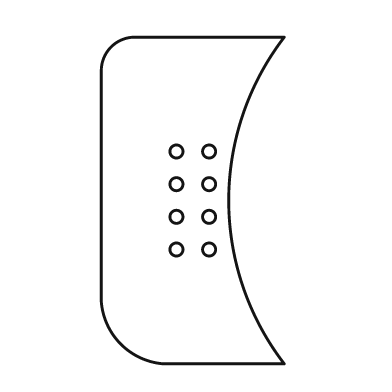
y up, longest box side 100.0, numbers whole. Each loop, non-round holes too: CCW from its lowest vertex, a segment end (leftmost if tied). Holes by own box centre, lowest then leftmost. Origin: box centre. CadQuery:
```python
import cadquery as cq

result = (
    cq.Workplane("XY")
    .moveTo(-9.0, -50.0)
    .lineTo(28.0, -50.0)
    .threePointArc((11.0, 0.0), (28.0, 50.0))
    .lineTo(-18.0, 50.0)
    .threePointArc((-25.0, 47.0), (-28.0, 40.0))
    .lineTo(-28.0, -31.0)
    .threePointArc((-22.0, -44.0), (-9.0, -50.0))
    .close()
    .moveTo(-5.0, -15.0)
    .circle(2.0)
    .moveTo(5.0, -15.0)
    .circle(2.0)
    .moveTo(-5.0, -5.0)
    .circle(2.0)
    .moveTo(5.0, -5.0)
    .circle(2.0)
    .moveTo(-5.0, 5.0)
    .circle(2.0)
    .moveTo(5.0, 5.0)
    .circle(2.0)
    .moveTo(-5.0, 15.0)
    .circle(2.0)
    .moveTo(5.0, 15.0)
    .circle(2.0)
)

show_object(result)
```